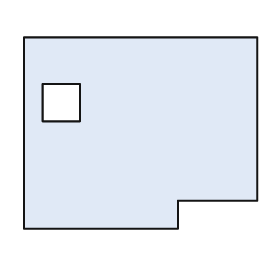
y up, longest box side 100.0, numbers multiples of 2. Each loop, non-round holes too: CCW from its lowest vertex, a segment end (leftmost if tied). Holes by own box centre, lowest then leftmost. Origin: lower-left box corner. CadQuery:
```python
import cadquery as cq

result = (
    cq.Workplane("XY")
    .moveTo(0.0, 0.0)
    .lineTo(66.0, 0.0)
    .lineTo(66.0, 12.0)
    .lineTo(100.0, 12.0)
    .lineTo(100.0, 82.0)
    .lineTo(0.0, 82.0)
    .close()
    .moveTo(8.0, 46.0)
    .lineTo(24.0, 46.0)
    .lineTo(24.0, 62.0)
    .lineTo(8.0, 62.0)
    .close()
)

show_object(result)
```